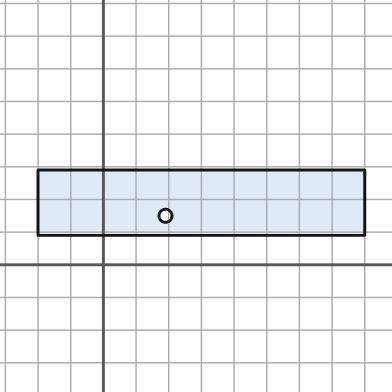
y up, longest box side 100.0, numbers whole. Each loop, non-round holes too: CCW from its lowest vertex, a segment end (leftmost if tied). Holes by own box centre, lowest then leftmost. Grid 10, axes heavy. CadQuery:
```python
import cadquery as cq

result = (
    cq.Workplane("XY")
    .moveTo(-20.0, 9.0)
    .lineTo(80.0, 9.0)
    .lineTo(80.0, 29.0)
    .lineTo(-20.0, 29.0)
    .close()
    .moveTo(19.0, 15.0)
    .circle(2.0)
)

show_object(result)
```